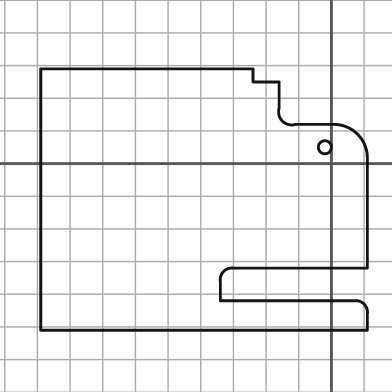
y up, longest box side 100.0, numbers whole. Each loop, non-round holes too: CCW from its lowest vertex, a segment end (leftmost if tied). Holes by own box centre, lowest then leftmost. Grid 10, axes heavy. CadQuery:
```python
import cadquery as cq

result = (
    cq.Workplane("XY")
    .moveTo(-89.0, -51.0)
    .lineTo(11.0, -51.0)
    .lineTo(11.0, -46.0)
    .threePointArc((10.0, -43.0), (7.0, -42.0))
    .lineTo(-34.0, -42.0)
    .lineTo(-34.0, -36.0)
    .threePointArc((-33.0, -33.0), (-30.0, -32.0))
    .lineTo(11.0, -32.0)
    .lineTo(11.0, 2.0)
    .threePointArc((8.0, 9.0), (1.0, 12.0))
    .lineTo(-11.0, 12.0)
    .threePointArc((-15.0, 13.0), (-16.0, 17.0))
    .lineTo(-16.0, 25.0)
    .lineTo(-24.0, 25.0)
    .lineTo(-24.0, 29.0)
    .lineTo(-89.0, 29.0)
    .close()
    .moveTo(-2.0, 5.0)
    .circle(2.0)
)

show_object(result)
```